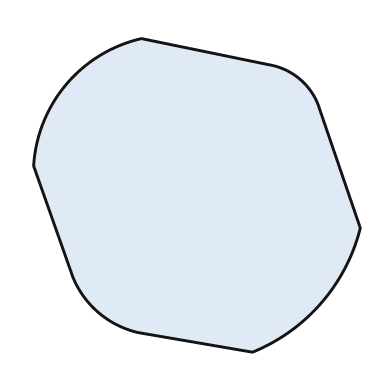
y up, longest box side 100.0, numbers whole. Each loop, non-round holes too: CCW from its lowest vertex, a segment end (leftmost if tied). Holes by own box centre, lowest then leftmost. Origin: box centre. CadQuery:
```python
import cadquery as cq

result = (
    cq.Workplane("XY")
    .moveTo(17.0, -48.0)
    .threePointArc((38.0, -33.0), (50.0, -10.0))
    .lineTo(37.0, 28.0)
    .threePointArc((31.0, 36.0), (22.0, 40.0))
    .lineTo(-17.0, 48.0)
    .threePointArc((-40.0, 34.0), (-50.0, 9.0))
    .lineTo(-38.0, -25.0)
    .threePointArc((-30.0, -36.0), (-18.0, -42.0))
    .close()
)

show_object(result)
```